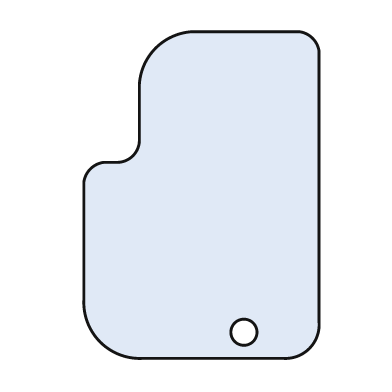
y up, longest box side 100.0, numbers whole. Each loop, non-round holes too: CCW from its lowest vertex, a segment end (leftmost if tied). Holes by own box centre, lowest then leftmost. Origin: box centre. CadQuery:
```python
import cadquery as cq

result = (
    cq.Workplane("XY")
    .moveTo(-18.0, -50.0)
    .lineTo(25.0, -50.0)
    .threePointArc((33.0, -47.0), (36.0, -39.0))
    .lineTo(36.0, 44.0)
    .threePointArc((34.0, 48.0), (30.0, 50.0))
    .lineTo(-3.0, 50.0)
    .threePointArc((-14.0, 45.0), (-19.0, 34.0))
    .lineTo(-19.0, 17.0)
    .threePointArc((-21.0, 12.0), (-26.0, 10.0))
    .lineTo(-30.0, 10.0)
    .threePointArc((-34.0, 8.0), (-36.0, 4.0))
    .lineTo(-36.0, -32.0)
    .threePointArc((-31.0, -45.0), (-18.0, -50.0))
    .close()
    .moveTo(13.0, -42.0)
    .circle(4.0)
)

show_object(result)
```